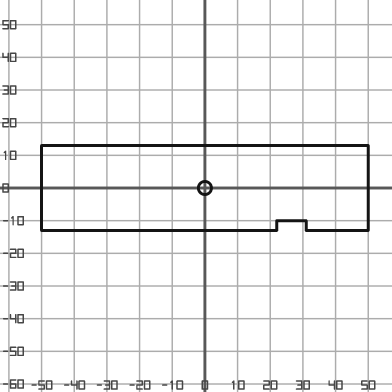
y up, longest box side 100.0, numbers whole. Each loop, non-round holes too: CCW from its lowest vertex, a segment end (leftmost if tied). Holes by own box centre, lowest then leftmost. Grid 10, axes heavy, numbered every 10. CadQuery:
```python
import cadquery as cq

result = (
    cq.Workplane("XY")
    .moveTo(-50.0, -13.0)
    .lineTo(22.0, -13.0)
    .lineTo(22.0, -10.0)
    .lineTo(31.0, -10.0)
    .lineTo(31.0, -13.0)
    .lineTo(50.0, -13.0)
    .lineTo(50.0, 13.0)
    .lineTo(-50.0, 13.0)
    .close()
    .moveTo(0.0, 0.0)
    .circle(2.0)
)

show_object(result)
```